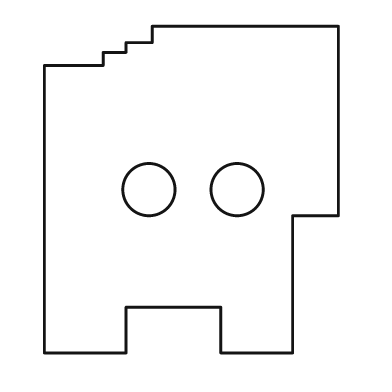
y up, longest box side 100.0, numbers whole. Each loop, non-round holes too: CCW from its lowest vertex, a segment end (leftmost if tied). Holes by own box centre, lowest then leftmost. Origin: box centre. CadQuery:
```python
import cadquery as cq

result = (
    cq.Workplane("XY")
    .moveTo(-45.0, -50.0)
    .lineTo(-20.0, -50.0)
    .lineTo(-20.0, -36.0)
    .lineTo(9.0, -36.0)
    .lineTo(9.0, -50.0)
    .lineTo(31.0, -50.0)
    .lineTo(31.0, -8.0)
    .lineTo(45.0, -8.0)
    .lineTo(45.0, 50.0)
    .lineTo(-12.0, 50.0)
    .lineTo(-12.0, 45.0)
    .lineTo(-20.0, 45.0)
    .lineTo(-20.0, 42.0)
    .lineTo(-27.0, 42.0)
    .lineTo(-27.0, 38.0)
    .lineTo(-45.0, 38.0)
    .close()
    .moveTo(-13.0, 0.0)
    .circle(8.0)
    .moveTo(14.0, 0.0)
    .circle(8.0)
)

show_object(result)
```